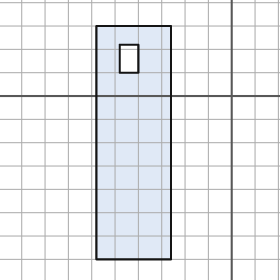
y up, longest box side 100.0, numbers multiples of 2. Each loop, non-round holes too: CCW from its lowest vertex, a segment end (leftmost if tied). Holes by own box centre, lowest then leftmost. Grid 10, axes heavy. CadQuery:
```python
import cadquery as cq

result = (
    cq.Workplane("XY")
    .moveTo(-58.0, -70.0)
    .lineTo(-26.0, -70.0)
    .lineTo(-26.0, 30.0)
    .lineTo(-58.0, 30.0)
    .close()
    .moveTo(-48.0, 10.0)
    .lineTo(-40.0, 10.0)
    .lineTo(-40.0, 22.0)
    .lineTo(-48.0, 22.0)
    .close()
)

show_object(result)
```